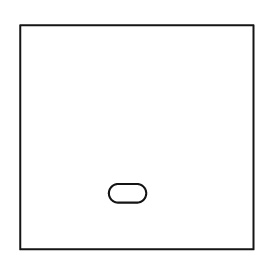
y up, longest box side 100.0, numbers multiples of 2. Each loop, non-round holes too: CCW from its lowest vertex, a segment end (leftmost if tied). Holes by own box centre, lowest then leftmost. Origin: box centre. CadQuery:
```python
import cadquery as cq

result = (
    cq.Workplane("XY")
    .moveTo(-50.0, -48.0)
    .lineTo(50.0, -48.0)
    .lineTo(50.0, 48.0)
    .lineTo(-50.0, 48.0)
    .close()
    .moveTo(-8.0, -28.0)
    .lineTo(0.0, -28.0)
    .threePointArc((4.0, -24.0), (0.0, -20.0))
    .lineTo(-8.0, -20.0)
    .threePointArc((-12.0, -24.0), (-8.0, -28.0))
    .close()
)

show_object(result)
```